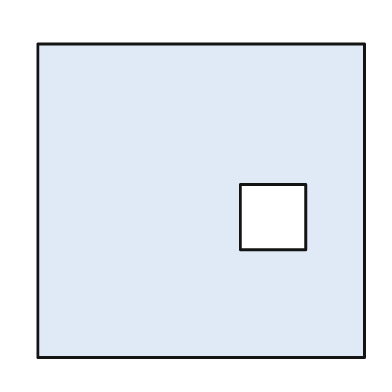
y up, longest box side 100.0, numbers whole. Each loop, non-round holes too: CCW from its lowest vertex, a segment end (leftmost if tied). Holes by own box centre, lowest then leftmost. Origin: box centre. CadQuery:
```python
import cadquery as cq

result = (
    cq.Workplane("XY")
    .moveTo(-50.0, -48.0)
    .lineTo(50.0, -48.0)
    .lineTo(50.0, 48.0)
    .lineTo(-50.0, 48.0)
    .close()
    .moveTo(12.0, -15.0)
    .lineTo(32.0, -15.0)
    .lineTo(32.0, 5.0)
    .lineTo(12.0, 5.0)
    .close()
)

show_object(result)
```